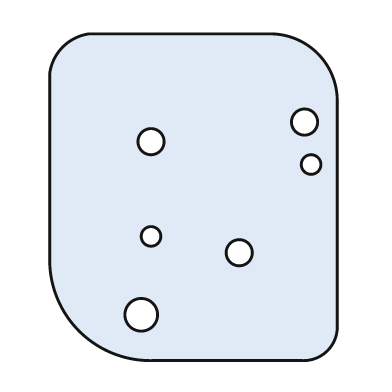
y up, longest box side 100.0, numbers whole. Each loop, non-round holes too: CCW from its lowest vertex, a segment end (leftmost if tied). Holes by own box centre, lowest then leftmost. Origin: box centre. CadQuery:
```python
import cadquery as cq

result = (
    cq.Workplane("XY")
    .moveTo(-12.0, -50.0)
    .lineTo(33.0, -50.0)
    .threePointArc((41.0, -47.0), (44.0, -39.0))
    .lineTo(44.0, 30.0)
    .threePointArc((38.0, 44.0), (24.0, 50.0))
    .lineTo(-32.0, 50.0)
    .threePointArc((-40.0, 46.0), (-44.0, 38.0))
    .lineTo(-44.0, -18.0)
    .threePointArc((-35.0, -41.0), (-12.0, -50.0))
    .close()
    .moveTo(-16.0, -36.0)
    .circle(5.0)
    .moveTo(14.0, -17.0)
    .circle(4.0)
    .moveTo(-13.0, -12.0)
    .circle(3.0)
    .moveTo(36.0, 10.0)
    .circle(3.0)
    .moveTo(-13.0, 17.0)
    .circle(4.0)
    .moveTo(34.0, 23.0)
    .circle(4.0)
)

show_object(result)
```